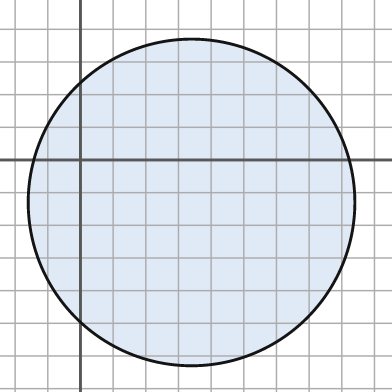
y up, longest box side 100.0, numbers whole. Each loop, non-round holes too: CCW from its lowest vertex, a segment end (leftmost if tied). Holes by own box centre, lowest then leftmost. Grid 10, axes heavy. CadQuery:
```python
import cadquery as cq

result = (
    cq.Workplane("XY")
    .moveTo(34.0, -13.0)
    .circle(50.0)
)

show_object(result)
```